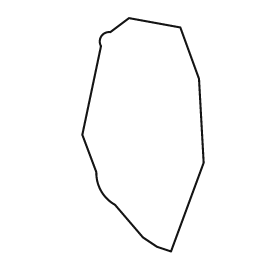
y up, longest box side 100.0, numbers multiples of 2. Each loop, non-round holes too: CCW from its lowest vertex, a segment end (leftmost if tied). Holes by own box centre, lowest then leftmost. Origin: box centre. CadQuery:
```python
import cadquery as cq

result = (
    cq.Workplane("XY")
    .moveTo(12.0, -50.0)
    .lineTo(26.0, -12.0)
    .lineTo(24.0, 24.0)
    .lineTo(16.0, 46.0)
    .lineTo(-6.0, 50.0)
    .lineTo(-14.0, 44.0)
    .threePointArc((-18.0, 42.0), (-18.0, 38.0))
    .lineTo(-26.0, 0.0)
    .lineTo(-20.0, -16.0)
    .threePointArc((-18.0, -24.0), (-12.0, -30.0))
    .lineTo(0.0, -44.0)
    .lineTo(6.0, -48.0)
    .close()
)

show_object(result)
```